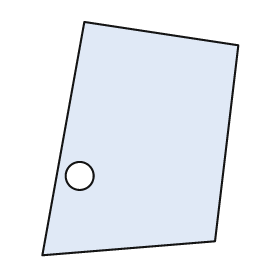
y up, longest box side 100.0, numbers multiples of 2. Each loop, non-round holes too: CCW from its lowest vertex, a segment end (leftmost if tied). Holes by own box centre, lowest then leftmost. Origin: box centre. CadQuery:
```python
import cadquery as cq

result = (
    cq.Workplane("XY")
    .moveTo(-42.0, -50.0)
    .lineTo(32.0, -44.0)
    .lineTo(42.0, 40.0)
    .lineTo(-24.0, 50.0)
    .close()
    .moveTo(-26.0, -16.0)
    .circle(6.0)
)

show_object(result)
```